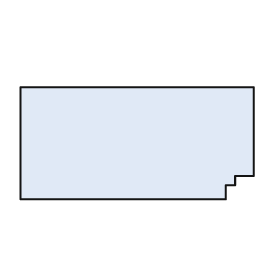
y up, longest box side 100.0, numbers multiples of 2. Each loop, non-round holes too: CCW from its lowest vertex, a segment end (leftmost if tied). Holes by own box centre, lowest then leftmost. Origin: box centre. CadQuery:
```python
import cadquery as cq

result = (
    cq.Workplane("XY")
    .moveTo(-50.0, -24.0)
    .lineTo(38.0, -24.0)
    .lineTo(38.0, -18.0)
    .lineTo(42.0, -18.0)
    .lineTo(42.0, -14.0)
    .lineTo(50.0, -14.0)
    .lineTo(50.0, 24.0)
    .lineTo(-50.0, 24.0)
    .close()
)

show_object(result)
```